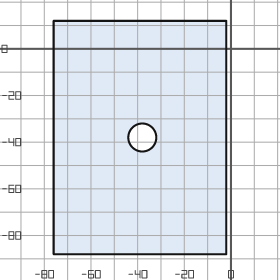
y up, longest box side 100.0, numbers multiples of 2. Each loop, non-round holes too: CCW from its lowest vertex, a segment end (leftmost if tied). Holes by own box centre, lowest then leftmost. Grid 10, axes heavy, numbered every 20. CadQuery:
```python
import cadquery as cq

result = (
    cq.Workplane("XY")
    .moveTo(-76.0, -88.0)
    .lineTo(-2.0, -88.0)
    .lineTo(-2.0, 12.0)
    .lineTo(-76.0, 12.0)
    .close()
    .moveTo(-38.0, -38.0)
    .circle(6.0)
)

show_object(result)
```